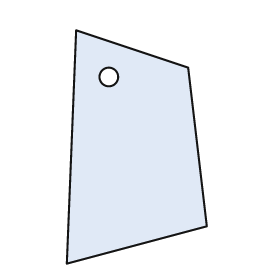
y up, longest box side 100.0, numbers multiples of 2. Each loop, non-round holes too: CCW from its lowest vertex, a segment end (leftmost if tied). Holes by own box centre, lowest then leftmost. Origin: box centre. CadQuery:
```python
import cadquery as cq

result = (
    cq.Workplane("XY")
    .moveTo(-30.0, -50.0)
    .lineTo(30.0, -34.0)
    .lineTo(22.0, 34.0)
    .lineTo(-26.0, 50.0)
    .close()
    .moveTo(-12.0, 30.0)
    .circle(4.0)
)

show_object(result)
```